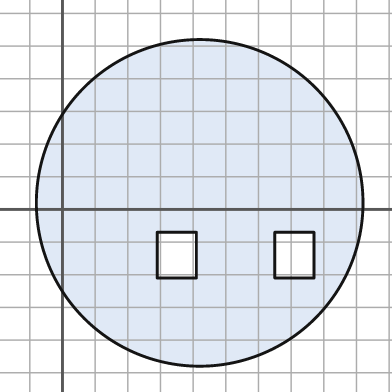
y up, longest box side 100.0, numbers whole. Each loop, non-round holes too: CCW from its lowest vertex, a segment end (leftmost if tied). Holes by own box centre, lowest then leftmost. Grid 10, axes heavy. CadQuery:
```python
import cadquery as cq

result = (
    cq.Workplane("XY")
    .moveTo(42.0, 2.0)
    .circle(50.0)
    .moveTo(29.0, -21.0)
    .lineTo(41.0, -21.0)
    .lineTo(41.0, -7.0)
    .lineTo(29.0, -7.0)
    .close()
    .moveTo(65.0, -21.0)
    .lineTo(77.0, -21.0)
    .lineTo(77.0, -7.0)
    .lineTo(65.0, -7.0)
    .close()
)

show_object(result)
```